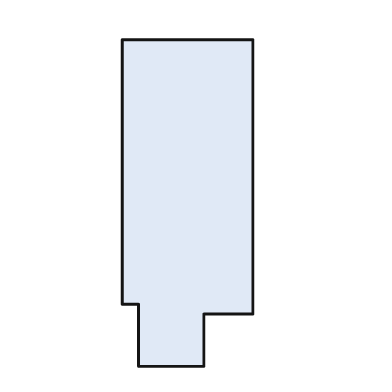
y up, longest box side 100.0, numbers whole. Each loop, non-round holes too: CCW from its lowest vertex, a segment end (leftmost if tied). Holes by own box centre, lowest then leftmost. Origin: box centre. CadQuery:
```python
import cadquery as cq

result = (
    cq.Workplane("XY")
    .moveTo(-15.0, -50.0)
    .lineTo(5.0, -50.0)
    .lineTo(5.0, -34.0)
    .lineTo(20.0, -34.0)
    .lineTo(20.0, 50.0)
    .lineTo(-20.0, 50.0)
    .lineTo(-20.0, -31.0)
    .lineTo(-15.0, -31.0)
    .close()
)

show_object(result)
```